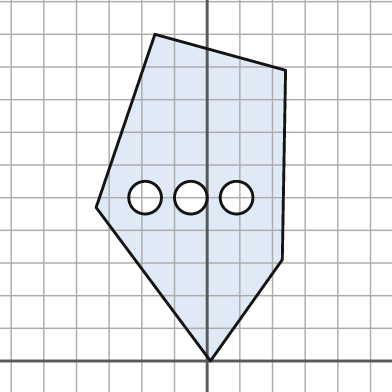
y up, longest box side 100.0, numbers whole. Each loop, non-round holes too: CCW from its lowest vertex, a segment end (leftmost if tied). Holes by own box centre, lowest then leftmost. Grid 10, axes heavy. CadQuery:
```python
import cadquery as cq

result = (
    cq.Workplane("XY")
    .moveTo(1.0, 0.0)
    .lineTo(23.0, 31.0)
    .lineTo(24.0, 89.0)
    .lineTo(-16.0, 100.0)
    .lineTo(-34.0, 47.0)
    .close()
    .moveTo(-19.0, 50.0)
    .circle(5.0)
    .moveTo(-5.0, 50.0)
    .circle(5.0)
    .moveTo(9.0, 50.0)
    .circle(5.0)
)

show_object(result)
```